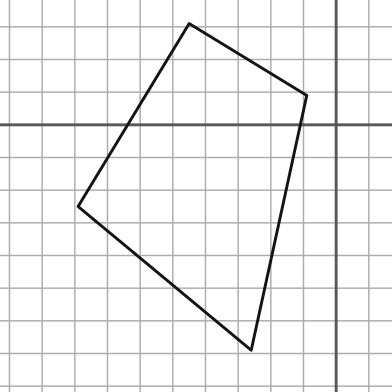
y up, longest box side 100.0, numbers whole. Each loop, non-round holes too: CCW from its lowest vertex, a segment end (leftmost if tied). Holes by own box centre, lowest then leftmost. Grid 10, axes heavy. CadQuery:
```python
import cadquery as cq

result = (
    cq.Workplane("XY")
    .moveTo(-26.0, -69.0)
    .lineTo(-9.0, 9.0)
    .lineTo(-45.0, 31.0)
    .lineTo(-79.0, -25.0)
    .close()
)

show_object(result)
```